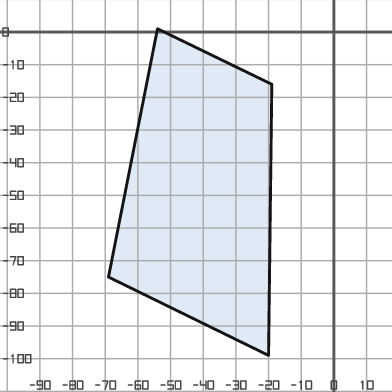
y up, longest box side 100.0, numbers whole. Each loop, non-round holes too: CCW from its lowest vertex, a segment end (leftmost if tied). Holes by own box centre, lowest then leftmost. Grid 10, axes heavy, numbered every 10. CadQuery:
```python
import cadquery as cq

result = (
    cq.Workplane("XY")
    .moveTo(-20.0, -99.0)
    .lineTo(-19.0, -16.0)
    .lineTo(-54.0, 1.0)
    .lineTo(-69.0, -75.0)
    .close()
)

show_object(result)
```